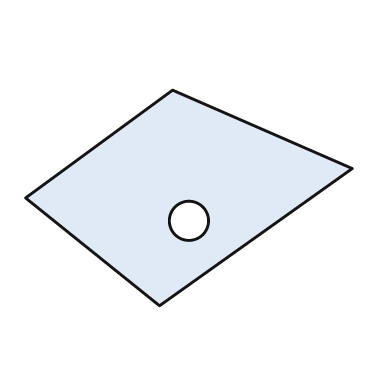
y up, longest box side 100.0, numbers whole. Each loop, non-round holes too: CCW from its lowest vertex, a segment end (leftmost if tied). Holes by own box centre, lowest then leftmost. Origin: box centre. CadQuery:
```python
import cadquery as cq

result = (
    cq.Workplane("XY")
    .moveTo(-9.0, -33.0)
    .lineTo(50.0, 9.0)
    .lineTo(-5.0, 33.0)
    .lineTo(-50.0, 0.0)
    .close()
    .moveTo(0.0, -7.0)
    .circle(6.0)
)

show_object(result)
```